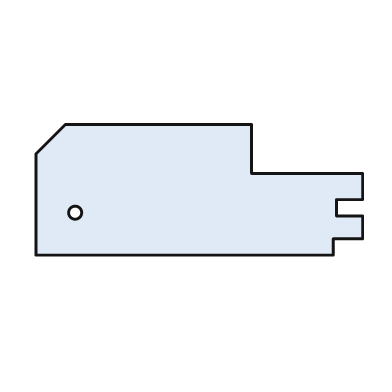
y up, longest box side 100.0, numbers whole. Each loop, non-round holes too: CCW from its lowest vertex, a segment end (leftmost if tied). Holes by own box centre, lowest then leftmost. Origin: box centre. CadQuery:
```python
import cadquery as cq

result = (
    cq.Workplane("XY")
    .moveTo(-50.0, -20.0)
    .lineTo(41.0, -20.0)
    .lineTo(41.0, -15.0)
    .lineTo(50.0, -15.0)
    .lineTo(50.0, -8.0)
    .lineTo(42.0, -8.0)
    .lineTo(42.0, -3.0)
    .lineTo(50.0, -3.0)
    .lineTo(50.0, 5.0)
    .lineTo(16.0, 5.0)
    .lineTo(16.0, 20.0)
    .lineTo(-41.0, 20.0)
    .lineTo(-50.0, 11.0)
    .close()
    .moveTo(-38.0, -7.0)
    .circle(2.0)
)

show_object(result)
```